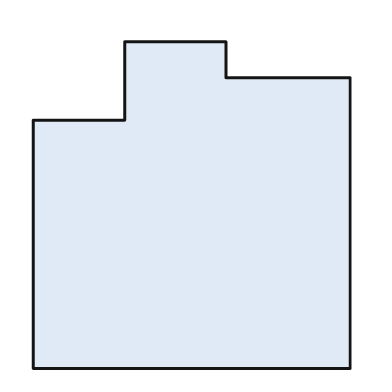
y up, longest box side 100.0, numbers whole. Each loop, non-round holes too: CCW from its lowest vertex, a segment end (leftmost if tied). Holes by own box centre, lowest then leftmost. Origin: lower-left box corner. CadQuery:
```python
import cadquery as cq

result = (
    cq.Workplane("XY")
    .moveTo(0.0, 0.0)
    .lineTo(97.0, 0.0)
    .lineTo(97.0, 89.0)
    .lineTo(59.0, 89.0)
    .lineTo(59.0, 100.0)
    .lineTo(28.0, 100.0)
    .lineTo(28.0, 76.0)
    .lineTo(0.0, 76.0)
    .close()
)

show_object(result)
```